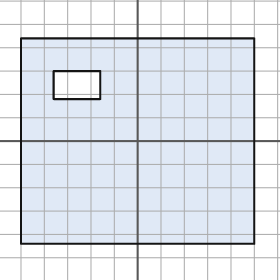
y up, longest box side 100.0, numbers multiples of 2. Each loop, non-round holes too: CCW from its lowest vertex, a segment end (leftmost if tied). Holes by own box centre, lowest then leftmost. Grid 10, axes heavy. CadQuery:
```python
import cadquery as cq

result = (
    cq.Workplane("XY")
    .moveTo(-50.0, -44.0)
    .lineTo(50.0, -44.0)
    .lineTo(50.0, 44.0)
    .lineTo(-50.0, 44.0)
    .close()
    .moveTo(-36.0, 18.0)
    .lineTo(-16.0, 18.0)
    .lineTo(-16.0, 30.0)
    .lineTo(-36.0, 30.0)
    .close()
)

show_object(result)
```